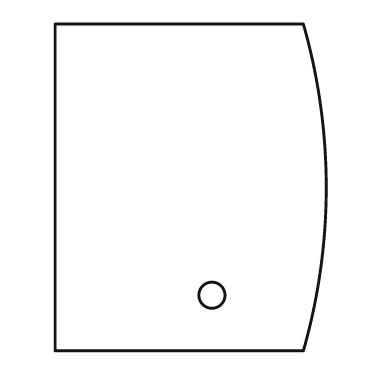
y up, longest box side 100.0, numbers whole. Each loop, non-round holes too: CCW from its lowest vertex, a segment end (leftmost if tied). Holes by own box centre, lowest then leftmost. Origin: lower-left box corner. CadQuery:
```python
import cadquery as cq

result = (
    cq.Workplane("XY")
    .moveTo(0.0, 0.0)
    .lineTo(76.0, 0.0)
    .threePointArc((83.0, 50.0), (76.0, 100.0))
    .lineTo(0.0, 100.0)
    .close()
    .moveTo(48.0, 17.0)
    .circle(4.0)
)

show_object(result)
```